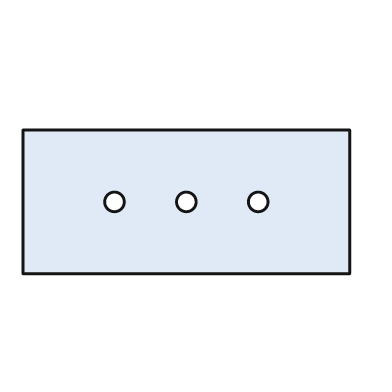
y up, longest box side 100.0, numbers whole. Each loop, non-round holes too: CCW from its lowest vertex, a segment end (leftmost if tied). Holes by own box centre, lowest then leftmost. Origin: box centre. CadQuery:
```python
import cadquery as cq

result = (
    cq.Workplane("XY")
    .moveTo(-50.0, -22.0)
    .lineTo(50.0, -22.0)
    .lineTo(50.0, 22.0)
    .lineTo(-50.0, 22.0)
    .close()
    .moveTo(-22.0, 0.0)
    .circle(3.0)
    .moveTo(0.0, 0.0)
    .circle(3.0)
    .moveTo(22.0, 0.0)
    .circle(3.0)
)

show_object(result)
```